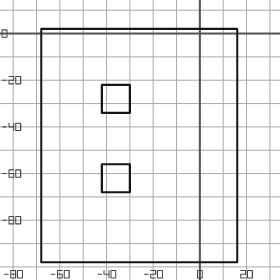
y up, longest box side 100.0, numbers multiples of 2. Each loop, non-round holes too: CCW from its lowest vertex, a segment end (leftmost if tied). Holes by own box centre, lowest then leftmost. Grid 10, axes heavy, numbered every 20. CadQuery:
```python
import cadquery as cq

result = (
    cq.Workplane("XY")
    .moveTo(-68.0, -98.0)
    .lineTo(16.0, -98.0)
    .lineTo(16.0, 2.0)
    .lineTo(-68.0, 2.0)
    .close()
    .moveTo(-42.0, -68.0)
    .lineTo(-30.0, -68.0)
    .lineTo(-30.0, -56.0)
    .lineTo(-42.0, -56.0)
    .close()
    .moveTo(-42.0, -34.0)
    .lineTo(-30.0, -34.0)
    .lineTo(-30.0, -22.0)
    .lineTo(-42.0, -22.0)
    .close()
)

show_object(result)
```